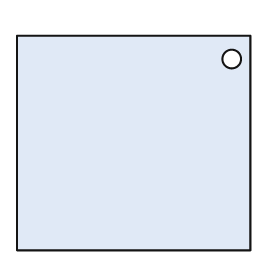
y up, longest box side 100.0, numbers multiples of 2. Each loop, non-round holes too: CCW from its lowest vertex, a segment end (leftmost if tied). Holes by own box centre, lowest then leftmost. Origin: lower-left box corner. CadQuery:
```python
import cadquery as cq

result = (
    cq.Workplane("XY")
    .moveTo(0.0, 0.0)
    .lineTo(100.0, 0.0)
    .lineTo(100.0, 92.0)
    .lineTo(0.0, 92.0)
    .close()
    .moveTo(92.0, 82.0)
    .circle(4.0)
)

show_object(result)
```